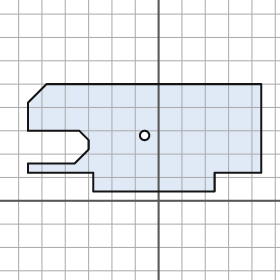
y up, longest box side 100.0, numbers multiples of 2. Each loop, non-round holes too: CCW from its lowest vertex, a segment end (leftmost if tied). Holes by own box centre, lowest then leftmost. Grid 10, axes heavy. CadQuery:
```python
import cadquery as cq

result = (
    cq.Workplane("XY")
    .moveTo(-28.0, 4.0)
    .lineTo(24.0, 4.0)
    .lineTo(24.0, 12.0)
    .lineTo(44.0, 12.0)
    .lineTo(44.0, 50.0)
    .lineTo(-48.0, 50.0)
    .lineTo(-56.0, 42.0)
    .lineTo(-56.0, 30.0)
    .lineTo(-34.0, 30.0)
    .lineTo(-30.0, 26.0)
    .lineTo(-30.0, 22.0)
    .lineTo(-36.0, 16.0)
    .lineTo(-56.0, 16.0)
    .lineTo(-56.0, 12.0)
    .lineTo(-28.0, 12.0)
    .close()
    .moveTo(-6.0, 28.0)
    .circle(2.0)
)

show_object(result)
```